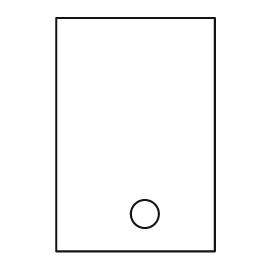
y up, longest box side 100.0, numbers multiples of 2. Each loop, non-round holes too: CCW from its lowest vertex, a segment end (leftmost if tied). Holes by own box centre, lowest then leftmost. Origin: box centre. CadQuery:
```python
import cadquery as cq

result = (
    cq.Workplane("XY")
    .moveTo(-34.0, -50.0)
    .lineTo(34.0, -50.0)
    .lineTo(34.0, 50.0)
    .lineTo(-34.0, 50.0)
    .close()
    .moveTo(4.0, -34.0)
    .circle(6.0)
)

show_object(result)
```